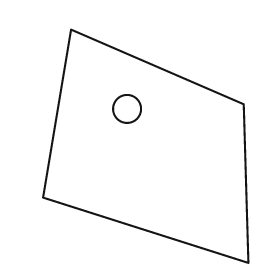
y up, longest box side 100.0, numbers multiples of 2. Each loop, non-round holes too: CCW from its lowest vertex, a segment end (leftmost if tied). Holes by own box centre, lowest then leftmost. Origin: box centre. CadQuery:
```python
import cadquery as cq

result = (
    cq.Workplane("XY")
    .moveTo(44.0, -50.0)
    .lineTo(42.0, 18.0)
    .lineTo(-32.0, 50.0)
    .lineTo(-44.0, -22.0)
    .close()
    .moveTo(-8.0, 16.0)
    .circle(6.0)
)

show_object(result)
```